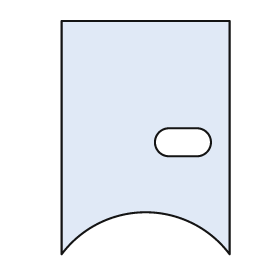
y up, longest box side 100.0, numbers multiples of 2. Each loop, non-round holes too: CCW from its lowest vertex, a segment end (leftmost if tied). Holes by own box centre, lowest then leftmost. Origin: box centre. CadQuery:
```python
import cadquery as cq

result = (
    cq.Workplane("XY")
    .moveTo(-36.0, -50.0)
    .threePointArc((0.0, -32.0), (36.0, -50.0))
    .lineTo(36.0, 50.0)
    .lineTo(-36.0, 50.0)
    .close()
    .moveTo(10.0, -8.0)
    .lineTo(22.0, -8.0)
    .threePointArc((28.0, -2.0), (22.0, 4.0))
    .lineTo(10.0, 4.0)
    .threePointArc((4.0, -2.0), (10.0, -8.0))
    .close()
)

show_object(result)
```